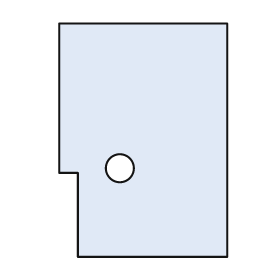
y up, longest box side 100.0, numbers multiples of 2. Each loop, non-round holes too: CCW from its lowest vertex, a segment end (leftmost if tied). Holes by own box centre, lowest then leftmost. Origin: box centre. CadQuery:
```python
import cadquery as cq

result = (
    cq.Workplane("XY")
    .moveTo(-28.0, -50.0)
    .lineTo(36.0, -50.0)
    .lineTo(36.0, 50.0)
    .lineTo(-36.0, 50.0)
    .lineTo(-36.0, -14.0)
    .lineTo(-28.0, -14.0)
    .close()
    .moveTo(-10.0, -12.0)
    .circle(6.0)
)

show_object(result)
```